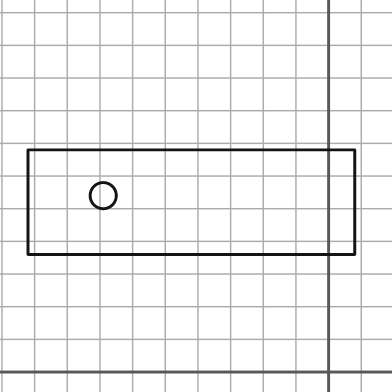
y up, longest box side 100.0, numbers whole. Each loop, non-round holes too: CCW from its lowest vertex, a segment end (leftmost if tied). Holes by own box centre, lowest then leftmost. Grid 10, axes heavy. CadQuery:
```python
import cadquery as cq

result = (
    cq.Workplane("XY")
    .moveTo(-92.0, 36.0)
    .lineTo(8.0, 36.0)
    .lineTo(8.0, 68.0)
    .lineTo(-92.0, 68.0)
    .close()
    .moveTo(-69.0, 54.0)
    .circle(4.0)
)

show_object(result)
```